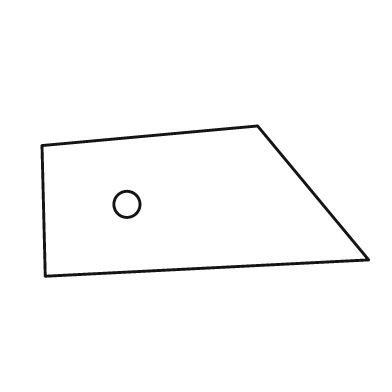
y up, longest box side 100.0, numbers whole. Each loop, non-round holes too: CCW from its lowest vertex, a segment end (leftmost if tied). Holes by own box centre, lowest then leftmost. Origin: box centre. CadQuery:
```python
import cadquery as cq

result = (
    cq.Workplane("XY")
    .moveTo(-49.0, -23.0)
    .lineTo(50.0, -18.0)
    .lineTo(16.0, 23.0)
    .lineTo(-50.0, 17.0)
    .close()
    .moveTo(-24.0, -1.0)
    .circle(4.0)
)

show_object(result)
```